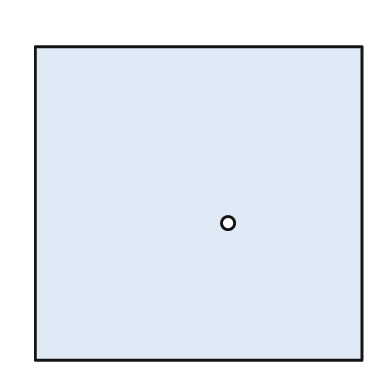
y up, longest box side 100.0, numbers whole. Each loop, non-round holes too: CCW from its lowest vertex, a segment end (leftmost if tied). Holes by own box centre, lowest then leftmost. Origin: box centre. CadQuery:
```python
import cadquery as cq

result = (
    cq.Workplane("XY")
    .moveTo(-50.0, -48.0)
    .lineTo(50.0, -48.0)
    .lineTo(50.0, 48.0)
    .lineTo(-50.0, 48.0)
    .close()
    .moveTo(9.0, -6.0)
    .circle(2.0)
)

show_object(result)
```